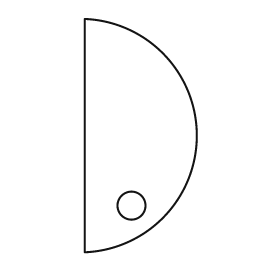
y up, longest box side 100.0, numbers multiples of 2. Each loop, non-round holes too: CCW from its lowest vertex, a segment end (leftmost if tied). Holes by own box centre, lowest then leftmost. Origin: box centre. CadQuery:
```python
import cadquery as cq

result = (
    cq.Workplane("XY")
    .moveTo(-24.0, -50.0)
    .threePointArc((24.0, 0.0), (-24.0, 50.0))
    .close()
    .moveTo(-4.0, -30.0)
    .circle(6.0)
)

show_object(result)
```